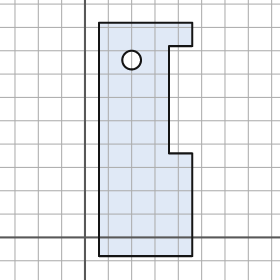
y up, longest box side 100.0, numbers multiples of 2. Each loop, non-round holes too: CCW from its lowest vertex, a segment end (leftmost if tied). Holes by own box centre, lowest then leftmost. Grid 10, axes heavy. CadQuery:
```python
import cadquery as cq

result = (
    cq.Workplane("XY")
    .moveTo(6.0, -8.0)
    .lineTo(46.0, -8.0)
    .lineTo(46.0, 36.0)
    .lineTo(36.0, 36.0)
    .lineTo(36.0, 82.0)
    .lineTo(46.0, 82.0)
    .lineTo(46.0, 92.0)
    .lineTo(6.0, 92.0)
    .close()
    .moveTo(20.0, 76.0)
    .circle(4.0)
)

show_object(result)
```